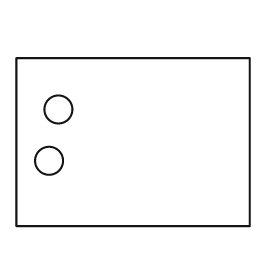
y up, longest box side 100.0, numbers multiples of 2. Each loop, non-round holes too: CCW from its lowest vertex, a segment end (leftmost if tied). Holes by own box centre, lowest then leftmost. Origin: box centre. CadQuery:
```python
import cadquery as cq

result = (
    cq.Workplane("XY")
    .moveTo(-50.0, -36.0)
    .lineTo(50.0, -36.0)
    .lineTo(50.0, 36.0)
    .lineTo(-50.0, 36.0)
    .close()
    .moveTo(-36.0, -8.0)
    .circle(6.0)
    .moveTo(-32.0, 14.0)
    .circle(6.0)
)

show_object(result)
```